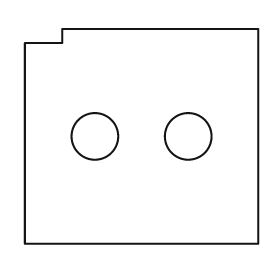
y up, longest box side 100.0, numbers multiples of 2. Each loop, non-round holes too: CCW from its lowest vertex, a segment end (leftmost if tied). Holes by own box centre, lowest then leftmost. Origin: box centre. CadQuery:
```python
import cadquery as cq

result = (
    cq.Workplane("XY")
    .moveTo(-50.0, -46.0)
    .lineTo(50.0, -46.0)
    .lineTo(50.0, 46.0)
    .lineTo(-34.0, 46.0)
    .lineTo(-34.0, 40.0)
    .lineTo(-50.0, 40.0)
    .close()
    .moveTo(-20.0, 0.0)
    .circle(10.0)
    .moveTo(20.0, 0.0)
    .circle(10.0)
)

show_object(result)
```